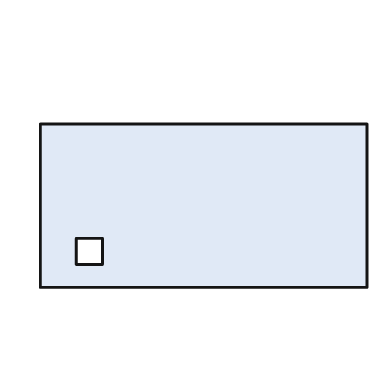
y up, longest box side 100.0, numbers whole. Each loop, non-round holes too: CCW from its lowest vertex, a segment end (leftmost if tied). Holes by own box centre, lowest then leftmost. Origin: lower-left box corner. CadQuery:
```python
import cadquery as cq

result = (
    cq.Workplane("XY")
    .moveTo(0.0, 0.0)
    .lineTo(100.0, 0.0)
    .lineTo(100.0, 50.0)
    .lineTo(0.0, 50.0)
    .close()
    .moveTo(11.0, 7.0)
    .lineTo(19.0, 7.0)
    .lineTo(19.0, 15.0)
    .lineTo(11.0, 15.0)
    .close()
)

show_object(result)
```